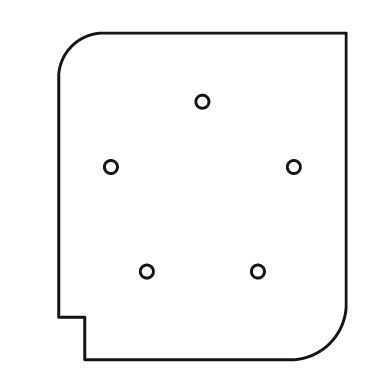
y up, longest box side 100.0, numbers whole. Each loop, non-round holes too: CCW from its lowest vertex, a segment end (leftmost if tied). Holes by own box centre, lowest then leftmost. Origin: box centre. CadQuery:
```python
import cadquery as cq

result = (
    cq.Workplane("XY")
    .moveTo(-36.0, -50.0)
    .lineTo(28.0, -50.0)
    .threePointArc((39.0, -45.0), (44.0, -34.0))
    .lineTo(44.0, 50.0)
    .lineTo(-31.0, 50.0)
    .threePointArc((-40.0, 46.0), (-44.0, 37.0))
    .lineTo(-44.0, -37.0)
    .lineTo(-36.0, -37.0)
    .close()
    .moveTo(-17.0, -23.0)
    .circle(2.0)
    .moveTo(17.0, -23.0)
    .circle(2.0)
    .moveTo(-28.0, 9.0)
    .circle(2.0)
    .moveTo(28.0, 9.0)
    .circle(2.0)
    .moveTo(0.0, 29.0)
    .circle(2.0)
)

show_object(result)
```